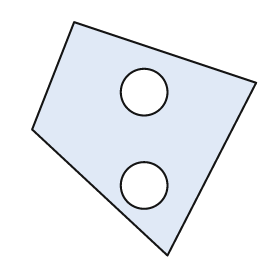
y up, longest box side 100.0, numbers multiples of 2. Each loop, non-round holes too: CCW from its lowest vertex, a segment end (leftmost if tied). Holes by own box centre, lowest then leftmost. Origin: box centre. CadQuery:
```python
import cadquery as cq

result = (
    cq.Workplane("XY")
    .moveTo(10.0, -50.0)
    .lineTo(48.0, 24.0)
    .lineTo(-30.0, 50.0)
    .lineTo(-48.0, 4.0)
    .close()
    .moveTo(0.0, -20.0)
    .circle(10.0)
    .moveTo(0.0, 20.0)
    .circle(10.0)
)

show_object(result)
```